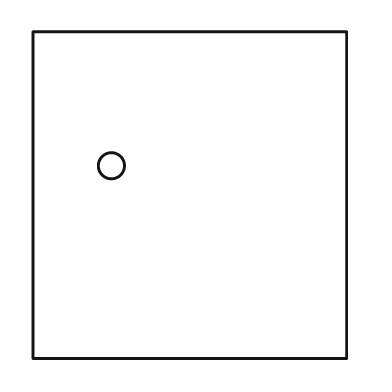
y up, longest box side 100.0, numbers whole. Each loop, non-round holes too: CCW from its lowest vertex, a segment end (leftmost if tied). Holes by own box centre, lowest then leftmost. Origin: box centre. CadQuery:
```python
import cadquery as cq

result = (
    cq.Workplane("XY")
    .moveTo(-48.0, -50.0)
    .lineTo(48.0, -50.0)
    .lineTo(48.0, 50.0)
    .lineTo(-48.0, 50.0)
    .close()
    .moveTo(-24.0, 9.0)
    .circle(4.0)
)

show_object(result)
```